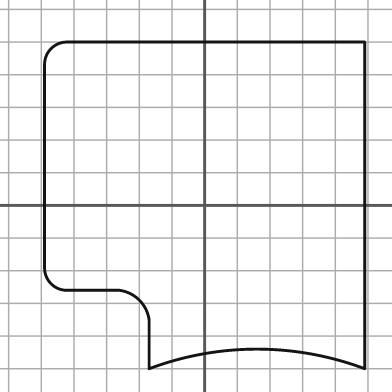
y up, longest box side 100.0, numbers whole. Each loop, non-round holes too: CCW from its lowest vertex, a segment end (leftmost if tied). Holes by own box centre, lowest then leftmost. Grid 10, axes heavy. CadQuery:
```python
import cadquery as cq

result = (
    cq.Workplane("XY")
    .moveTo(-17.0, -50.0)
    .threePointArc((16.0, -44.0), (49.0, -50.0))
    .lineTo(49.0, 50.0)
    .lineTo(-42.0, 50.0)
    .threePointArc((-47.0, 48.0), (-49.0, 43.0))
    .lineTo(-49.0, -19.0)
    .threePointArc((-47.0, -24.0), (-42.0, -26.0))
    .lineTo(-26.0, -26.0)
    .threePointArc((-20.0, -29.0), (-17.0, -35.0))
    .close()
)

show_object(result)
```